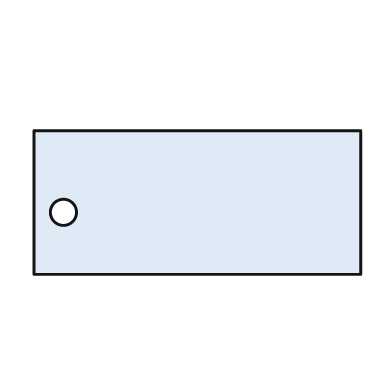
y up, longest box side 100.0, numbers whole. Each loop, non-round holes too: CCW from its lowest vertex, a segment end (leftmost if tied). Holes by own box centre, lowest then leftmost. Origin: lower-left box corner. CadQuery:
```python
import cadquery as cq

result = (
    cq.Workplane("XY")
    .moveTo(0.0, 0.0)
    .lineTo(100.0, 0.0)
    .lineTo(100.0, 44.0)
    .lineTo(0.0, 44.0)
    .close()
    .moveTo(9.0, 19.0)
    .circle(4.0)
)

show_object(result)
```